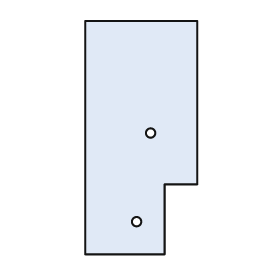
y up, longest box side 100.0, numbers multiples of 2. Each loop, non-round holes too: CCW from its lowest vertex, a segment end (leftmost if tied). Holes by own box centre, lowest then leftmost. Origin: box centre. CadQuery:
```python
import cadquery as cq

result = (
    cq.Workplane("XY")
    .moveTo(-24.0, -50.0)
    .lineTo(10.0, -50.0)
    .lineTo(10.0, -20.0)
    .lineTo(24.0, -20.0)
    .lineTo(24.0, 50.0)
    .lineTo(-24.0, 50.0)
    .close()
    .moveTo(-2.0, -36.0)
    .circle(2.0)
    .moveTo(4.0, 2.0)
    .circle(2.0)
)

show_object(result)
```